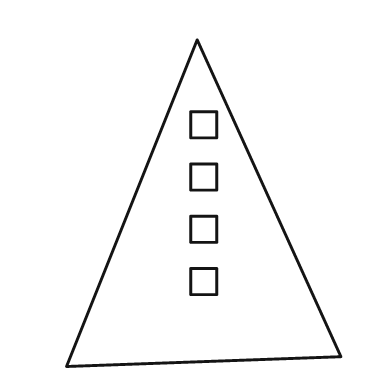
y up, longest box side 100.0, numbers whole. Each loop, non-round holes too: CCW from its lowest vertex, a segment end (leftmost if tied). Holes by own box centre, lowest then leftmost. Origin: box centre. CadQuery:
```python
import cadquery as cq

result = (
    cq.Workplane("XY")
    .moveTo(-42.0, -50.0)
    .lineTo(42.0, -47.0)
    .lineTo(-2.0, 50.0)
    .close()
    .moveTo(-4.0, -28.0)
    .lineTo(4.0, -28.0)
    .lineTo(4.0, -20.0)
    .lineTo(-4.0, -20.0)
    .close()
    .moveTo(-4.0, -12.0)
    .lineTo(4.0, -12.0)
    .lineTo(4.0, -4.0)
    .lineTo(-4.0, -4.0)
    .close()
    .moveTo(-4.0, 4.0)
    .lineTo(4.0, 4.0)
    .lineTo(4.0, 12.0)
    .lineTo(-4.0, 12.0)
    .close()
    .moveTo(-4.0, 20.0)
    .lineTo(4.0, 20.0)
    .lineTo(4.0, 28.0)
    .lineTo(-4.0, 28.0)
    .close()
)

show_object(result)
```